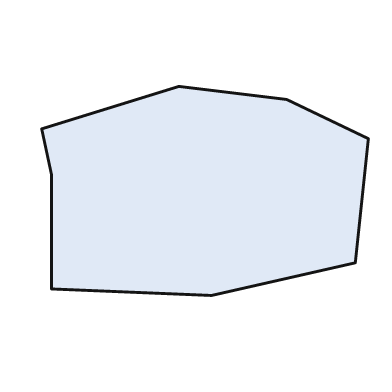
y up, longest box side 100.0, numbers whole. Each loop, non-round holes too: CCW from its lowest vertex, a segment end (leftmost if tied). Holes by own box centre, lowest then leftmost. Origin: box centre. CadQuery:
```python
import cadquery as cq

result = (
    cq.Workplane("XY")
    .moveTo(2.0, -32.0)
    .lineTo(46.0, -22.0)
    .lineTo(50.0, 16.0)
    .lineTo(25.0, 28.0)
    .lineTo(-8.0, 32.0)
    .lineTo(-50.0, 19.0)
    .lineTo(-47.0, 5.0)
    .lineTo(-47.0, -30.0)
    .close()
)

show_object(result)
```